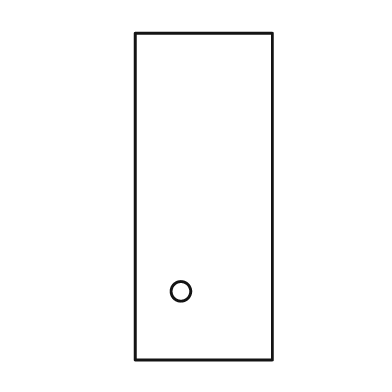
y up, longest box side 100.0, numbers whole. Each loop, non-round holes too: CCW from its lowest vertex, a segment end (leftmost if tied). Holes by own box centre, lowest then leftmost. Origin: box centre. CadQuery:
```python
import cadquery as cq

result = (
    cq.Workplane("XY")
    .moveTo(-21.0, -50.0)
    .lineTo(21.0, -50.0)
    .lineTo(21.0, 50.0)
    .lineTo(-21.0, 50.0)
    .close()
    .moveTo(-7.0, -29.0)
    .circle(3.0)
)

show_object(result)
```